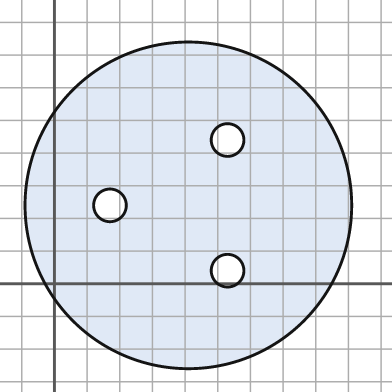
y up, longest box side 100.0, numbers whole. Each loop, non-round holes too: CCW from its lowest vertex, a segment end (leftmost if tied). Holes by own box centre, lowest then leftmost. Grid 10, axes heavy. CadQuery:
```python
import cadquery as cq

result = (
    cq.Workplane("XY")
    .moveTo(41.0, 24.0)
    .circle(50.0)
    .moveTo(53.0, 4.0)
    .circle(5.0)
    .moveTo(17.0, 24.0)
    .circle(5.0)
    .moveTo(53.0, 44.0)
    .circle(5.0)
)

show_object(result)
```